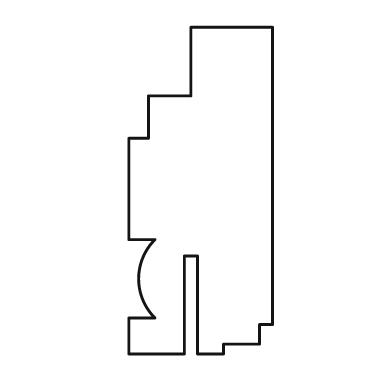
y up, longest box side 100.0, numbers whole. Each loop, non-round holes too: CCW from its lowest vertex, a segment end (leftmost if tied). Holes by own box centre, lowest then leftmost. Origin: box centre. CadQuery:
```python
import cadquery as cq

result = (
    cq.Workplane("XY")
    .moveTo(-22.0, -50.0)
    .lineTo(-5.0, -50.0)
    .lineTo(-5.0, -20.0)
    .lineTo(-1.0, -20.0)
    .lineTo(-1.0, -50.0)
    .lineTo(7.0, -50.0)
    .lineTo(7.0, -47.0)
    .lineTo(18.0, -47.0)
    .lineTo(18.0, -41.0)
    .lineTo(22.0, -41.0)
    .lineTo(22.0, 50.0)
    .lineTo(-3.0, 50.0)
    .lineTo(-3.0, 29.0)
    .lineTo(-16.0, 29.0)
    .lineTo(-16.0, 16.0)
    .lineTo(-22.0, 16.0)
    .lineTo(-22.0, -15.0)
    .lineTo(-14.0, -15.0)
    .threePointArc((-19.0, -27.0), (-14.0, -39.0))
    .lineTo(-22.0, -39.0)
    .close()
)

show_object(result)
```